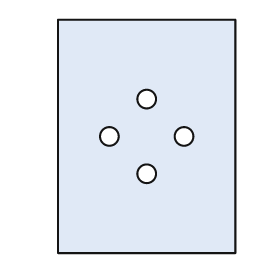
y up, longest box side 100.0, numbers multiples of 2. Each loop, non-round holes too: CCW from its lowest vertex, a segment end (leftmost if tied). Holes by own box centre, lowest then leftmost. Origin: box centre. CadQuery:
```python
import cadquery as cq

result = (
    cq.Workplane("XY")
    .moveTo(-38.0, -50.0)
    .lineTo(38.0, -50.0)
    .lineTo(38.0, 50.0)
    .lineTo(-38.0, 50.0)
    .close()
    .moveTo(0.0, -16.0)
    .circle(4.0)
    .moveTo(-16.0, 0.0)
    .circle(4.0)
    .moveTo(16.0, 0.0)
    .circle(4.0)
    .moveTo(0.0, 16.0)
    .circle(4.0)
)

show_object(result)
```